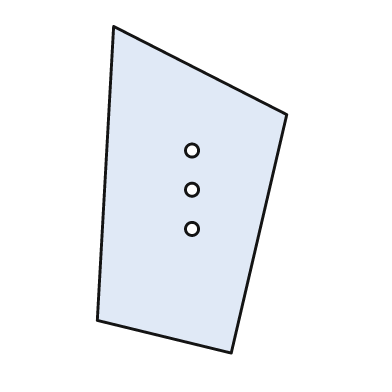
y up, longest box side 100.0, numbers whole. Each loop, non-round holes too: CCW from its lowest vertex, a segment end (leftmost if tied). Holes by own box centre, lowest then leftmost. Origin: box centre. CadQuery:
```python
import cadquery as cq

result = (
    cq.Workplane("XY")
    .moveTo(12.0, -50.0)
    .lineTo(29.0, 23.0)
    .lineTo(-24.0, 50.0)
    .lineTo(-29.0, -40.0)
    .close()
    .moveTo(0.0, -12.0)
    .circle(2.0)
    .moveTo(0.0, 0.0)
    .circle(2.0)
    .moveTo(0.0, 12.0)
    .circle(2.0)
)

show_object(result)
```